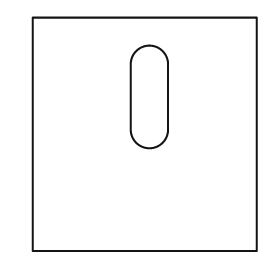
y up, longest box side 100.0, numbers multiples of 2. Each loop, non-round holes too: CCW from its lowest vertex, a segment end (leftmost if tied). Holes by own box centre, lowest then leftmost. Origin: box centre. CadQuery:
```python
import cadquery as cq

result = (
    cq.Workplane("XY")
    .moveTo(-48.0, -50.0)
    .lineTo(48.0, -50.0)
    .lineTo(48.0, 50.0)
    .lineTo(-48.0, 50.0)
    .close()
    .moveTo(-6.0, 2.0)
    .threePointArc((2.0, -6.0), (10.0, 2.0))
    .lineTo(10.0, 30.0)
    .threePointArc((2.0, 38.0), (-6.0, 30.0))
    .close()
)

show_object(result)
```